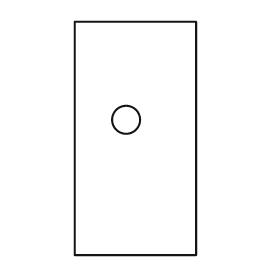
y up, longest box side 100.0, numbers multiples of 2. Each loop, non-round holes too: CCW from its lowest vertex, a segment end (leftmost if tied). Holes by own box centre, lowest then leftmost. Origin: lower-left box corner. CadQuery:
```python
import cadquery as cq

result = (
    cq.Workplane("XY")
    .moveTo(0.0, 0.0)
    .lineTo(52.0, 0.0)
    .lineTo(52.0, 100.0)
    .lineTo(0.0, 100.0)
    .close()
    .moveTo(22.0, 58.0)
    .circle(6.0)
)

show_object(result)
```